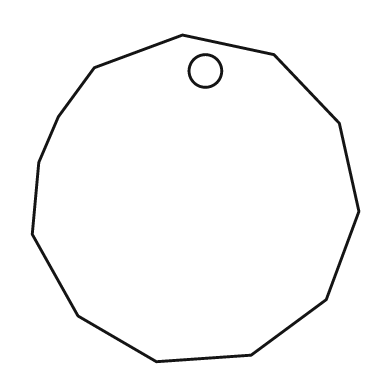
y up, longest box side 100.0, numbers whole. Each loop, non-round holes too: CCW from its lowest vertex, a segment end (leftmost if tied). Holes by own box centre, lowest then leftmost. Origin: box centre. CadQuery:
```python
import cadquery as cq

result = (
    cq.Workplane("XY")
    .moveTo(-12.0, -50.0)
    .lineTo(17.0, -48.0)
    .lineTo(40.0, -31.0)
    .lineTo(50.0, -4.0)
    .lineTo(44.0, 23.0)
    .lineTo(24.0, 44.0)
    .lineTo(-4.0, 50.0)
    .lineTo(-31.0, 40.0)
    .lineTo(-42.0, 25.0)
    .lineTo(-48.0, 11.0)
    .lineTo(-50.0, -11.0)
    .lineTo(-36.0, -36.0)
    .close()
    .moveTo(3.0, 39.0)
    .circle(5.0)
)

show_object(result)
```